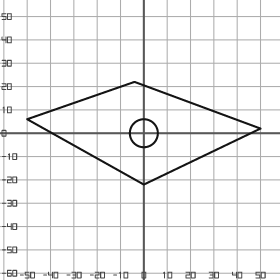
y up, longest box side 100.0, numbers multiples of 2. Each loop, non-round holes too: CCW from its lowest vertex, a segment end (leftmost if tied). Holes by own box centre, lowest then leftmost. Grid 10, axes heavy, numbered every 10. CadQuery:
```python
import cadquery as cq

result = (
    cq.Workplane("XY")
    .moveTo(0.0, -22.0)
    .lineTo(50.0, 2.0)
    .lineTo(-4.0, 22.0)
    .lineTo(-50.0, 6.0)
    .close()
    .moveTo(0.0, 0.0)
    .circle(6.0)
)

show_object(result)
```